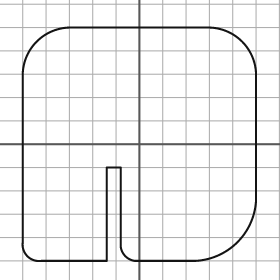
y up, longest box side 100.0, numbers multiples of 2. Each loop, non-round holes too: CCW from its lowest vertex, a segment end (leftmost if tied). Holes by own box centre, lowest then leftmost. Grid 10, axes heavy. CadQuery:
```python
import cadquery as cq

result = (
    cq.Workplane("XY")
    .moveTo(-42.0, -50.0)
    .lineTo(-14.0, -50.0)
    .lineTo(-14.0, -10.0)
    .lineTo(-8.0, -10.0)
    .lineTo(-8.0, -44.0)
    .threePointArc((-6.0, -48.0), (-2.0, -50.0))
    .lineTo(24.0, -50.0)
    .threePointArc((42.0, -42.0), (50.0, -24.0))
    .lineTo(50.0, 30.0)
    .threePointArc((44.0, 44.0), (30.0, 50.0))
    .lineTo(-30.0, 50.0)
    .threePointArc((-44.0, 44.0), (-50.0, 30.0))
    .lineTo(-50.0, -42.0)
    .threePointArc((-48.0, -48.0), (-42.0, -50.0))
    .close()
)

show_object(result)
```